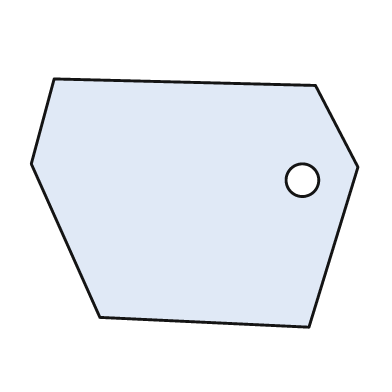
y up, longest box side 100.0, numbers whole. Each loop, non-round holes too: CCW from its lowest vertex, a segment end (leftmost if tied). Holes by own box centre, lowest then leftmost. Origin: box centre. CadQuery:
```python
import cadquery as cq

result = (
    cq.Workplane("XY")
    .moveTo(35.0, -38.0)
    .lineTo(50.0, 11.0)
    .lineTo(37.0, 36.0)
    .lineTo(-43.0, 38.0)
    .lineTo(-50.0, 12.0)
    .lineTo(-29.0, -35.0)
    .close()
    .moveTo(33.0, 7.0)
    .circle(5.0)
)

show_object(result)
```